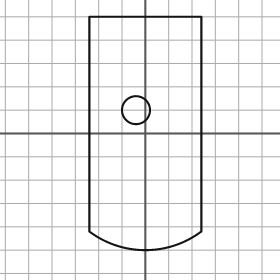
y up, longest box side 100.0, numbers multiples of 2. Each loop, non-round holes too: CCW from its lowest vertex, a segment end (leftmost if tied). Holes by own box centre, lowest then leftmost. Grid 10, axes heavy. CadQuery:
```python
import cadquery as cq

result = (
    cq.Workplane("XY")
    .moveTo(-24.0, -42.0)
    .threePointArc((0.0, -50.0), (24.0, -42.0))
    .lineTo(24.0, 50.0)
    .lineTo(-24.0, 50.0)
    .close()
    .moveTo(-4.0, 10.0)
    .circle(6.0)
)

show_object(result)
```